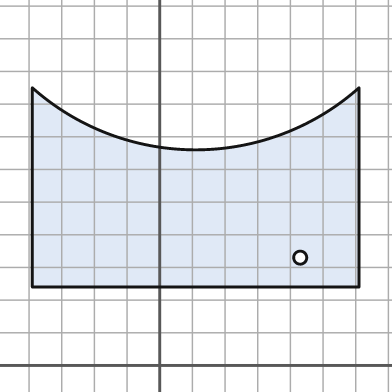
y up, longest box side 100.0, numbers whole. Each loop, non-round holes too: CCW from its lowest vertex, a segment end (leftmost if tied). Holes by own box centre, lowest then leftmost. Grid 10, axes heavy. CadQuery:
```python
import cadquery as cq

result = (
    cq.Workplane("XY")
    .moveTo(-39.0, 24.0)
    .lineTo(61.0, 24.0)
    .lineTo(61.0, 85.0)
    .threePointArc((11.0, 66.0), (-39.0, 85.0))
    .close()
    .moveTo(43.0, 33.0)
    .circle(2.0)
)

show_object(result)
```